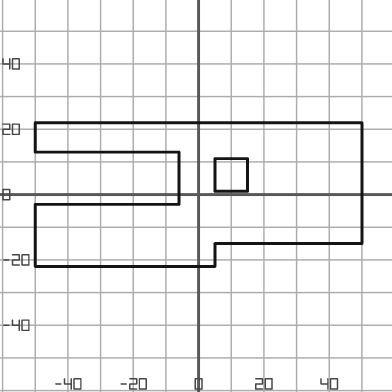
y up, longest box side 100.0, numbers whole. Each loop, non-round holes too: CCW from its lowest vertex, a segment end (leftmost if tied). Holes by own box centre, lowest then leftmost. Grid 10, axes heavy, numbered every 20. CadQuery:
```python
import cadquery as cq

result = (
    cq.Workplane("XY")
    .moveTo(-50.0, -22.0)
    .lineTo(5.0, -22.0)
    .lineTo(5.0, -15.0)
    .lineTo(50.0, -15.0)
    .lineTo(50.0, 22.0)
    .lineTo(-50.0, 22.0)
    .lineTo(-50.0, 13.0)
    .lineTo(-6.0, 13.0)
    .lineTo(-6.0, -3.0)
    .lineTo(-50.0, -3.0)
    .close()
    .moveTo(5.0, 1.0)
    .lineTo(15.0, 1.0)
    .lineTo(15.0, 11.0)
    .lineTo(5.0, 11.0)
    .close()
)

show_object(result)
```